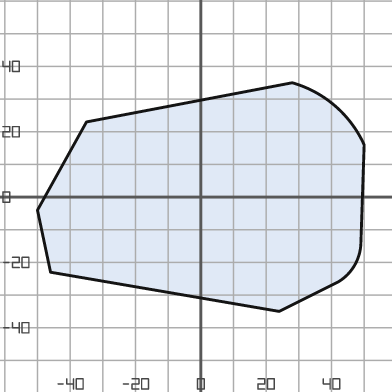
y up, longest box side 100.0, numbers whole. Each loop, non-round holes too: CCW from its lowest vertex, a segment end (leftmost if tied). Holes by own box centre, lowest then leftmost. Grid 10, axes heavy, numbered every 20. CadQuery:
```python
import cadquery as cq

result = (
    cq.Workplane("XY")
    .moveTo(24.0, -35.0)
    .lineTo(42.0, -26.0)
    .threePointArc((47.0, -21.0), (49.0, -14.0))
    .lineTo(50.0, 16.0)
    .threePointArc((41.0, 28.0), (28.0, 35.0))
    .lineTo(-35.0, 23.0)
    .lineTo(-50.0, -4.0)
    .lineTo(-46.0, -23.0)
    .close()
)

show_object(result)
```